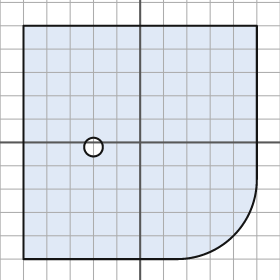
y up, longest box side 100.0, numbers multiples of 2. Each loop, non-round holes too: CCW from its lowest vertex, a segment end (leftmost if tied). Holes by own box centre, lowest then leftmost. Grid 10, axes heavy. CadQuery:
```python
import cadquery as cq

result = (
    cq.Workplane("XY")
    .moveTo(-50.0, -50.0)
    .lineTo(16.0, -50.0)
    .threePointArc((40.0, -40.0), (50.0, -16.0))
    .lineTo(50.0, 50.0)
    .lineTo(-50.0, 50.0)
    .close()
    .moveTo(-20.0, -2.0)
    .circle(4.0)
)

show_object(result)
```